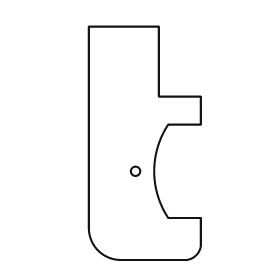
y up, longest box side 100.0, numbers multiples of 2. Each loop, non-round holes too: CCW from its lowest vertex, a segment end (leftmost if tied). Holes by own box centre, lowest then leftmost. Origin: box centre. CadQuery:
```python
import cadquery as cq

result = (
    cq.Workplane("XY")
    .moveTo(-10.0, -50.0)
    .lineTo(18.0, -50.0)
    .threePointArc((22.0, -48.0), (24.0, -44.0))
    .lineTo(24.0, -32.0)
    .lineTo(10.0, -32.0)
    .threePointArc((4.0, -12.0), (10.0, 8.0))
    .lineTo(24.0, 8.0)
    .lineTo(24.0, 20.0)
    .lineTo(6.0, 20.0)
    .lineTo(6.0, 50.0)
    .lineTo(-24.0, 50.0)
    .lineTo(-24.0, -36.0)
    .threePointArc((-20.0, -46.0), (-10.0, -50.0))
    .close()
    .moveTo(-4.0, -12.0)
    .circle(2.0)
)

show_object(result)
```